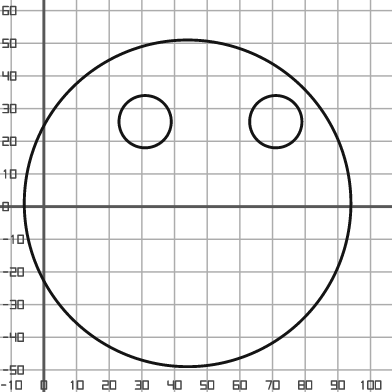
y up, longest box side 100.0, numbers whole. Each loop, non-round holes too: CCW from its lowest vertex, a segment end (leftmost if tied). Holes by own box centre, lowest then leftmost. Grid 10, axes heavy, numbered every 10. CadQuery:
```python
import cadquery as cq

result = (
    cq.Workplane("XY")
    .moveTo(44.0, 1.0)
    .circle(50.0)
    .moveTo(31.0, 26.0)
    .circle(8.0)
    .moveTo(71.0, 26.0)
    .circle(8.0)
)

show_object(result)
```